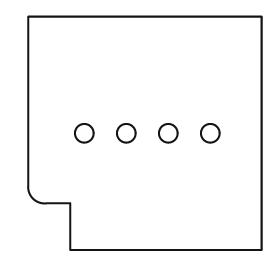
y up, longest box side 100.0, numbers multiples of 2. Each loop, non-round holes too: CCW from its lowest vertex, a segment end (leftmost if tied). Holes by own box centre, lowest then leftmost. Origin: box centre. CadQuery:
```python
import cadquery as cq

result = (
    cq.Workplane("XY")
    .moveTo(-32.0, -50.0)
    .lineTo(50.0, -50.0)
    .lineTo(50.0, 50.0)
    .lineTo(-50.0, 50.0)
    .lineTo(-50.0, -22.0)
    .threePointArc((-48.0, -28.0), (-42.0, -30.0))
    .lineTo(-32.0, -30.0)
    .close()
    .moveTo(-26.0, 0.0)
    .circle(4.0)
    .moveTo(-8.0, 0.0)
    .circle(4.0)
    .moveTo(10.0, 0.0)
    .circle(4.0)
    .moveTo(28.0, 0.0)
    .circle(4.0)
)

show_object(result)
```